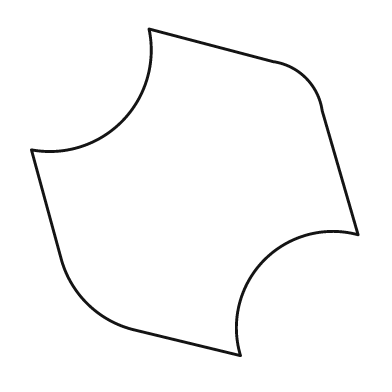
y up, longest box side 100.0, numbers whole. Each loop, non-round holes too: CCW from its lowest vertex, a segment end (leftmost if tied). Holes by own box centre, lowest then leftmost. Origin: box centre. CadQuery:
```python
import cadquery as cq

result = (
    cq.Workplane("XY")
    .moveTo(14.0, -50.0)
    .threePointArc((21.0, -21.0), (50.0, -13.0))
    .lineTo(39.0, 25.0)
    .threePointArc((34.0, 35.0), (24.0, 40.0))
    .lineTo(-14.0, 50.0)
    .threePointArc((-22.0, 22.0), (-50.0, 13.0))
    .lineTo(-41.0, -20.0)
    .threePointArc((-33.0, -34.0), (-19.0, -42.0))
    .close()
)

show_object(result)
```